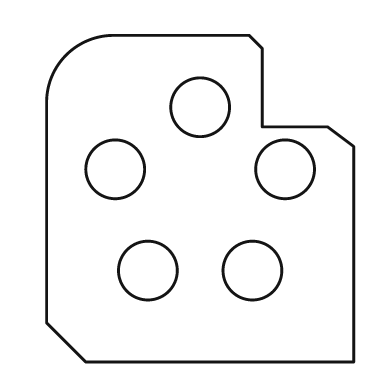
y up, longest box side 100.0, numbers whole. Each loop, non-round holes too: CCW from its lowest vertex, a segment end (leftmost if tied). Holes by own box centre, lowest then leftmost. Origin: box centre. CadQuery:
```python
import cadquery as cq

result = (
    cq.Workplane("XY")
    .moveTo(-35.0, -50.0)
    .lineTo(47.0, -50.0)
    .lineTo(47.0, 16.0)
    .lineTo(39.0, 22.0)
    .lineTo(19.0, 22.0)
    .lineTo(19.0, 46.0)
    .lineTo(15.0, 50.0)
    .lineTo(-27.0, 50.0)
    .threePointArc((-41.0, 44.0), (-47.0, 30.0))
    .lineTo(-47.0, -38.0)
    .close()
    .moveTo(-16.0, -22.0)
    .circle(9.0)
    .moveTo(16.0, -22.0)
    .circle(9.0)
    .moveTo(-26.0, 9.0)
    .circle(9.0)
    .moveTo(26.0, 9.0)
    .circle(9.0)
    .moveTo(0.0, 28.0)
    .circle(9.0)
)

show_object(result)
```